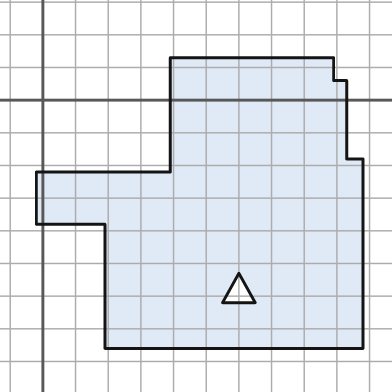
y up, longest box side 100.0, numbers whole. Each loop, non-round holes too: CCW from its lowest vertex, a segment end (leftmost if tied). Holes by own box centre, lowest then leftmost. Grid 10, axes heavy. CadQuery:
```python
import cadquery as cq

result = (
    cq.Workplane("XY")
    .moveTo(19.0, -76.0)
    .lineTo(98.0, -76.0)
    .lineTo(98.0, -18.0)
    .lineTo(93.0, -18.0)
    .lineTo(93.0, 6.0)
    .lineTo(89.0, 6.0)
    .lineTo(89.0, 13.0)
    .lineTo(39.0, 13.0)
    .lineTo(39.0, -22.0)
    .lineTo(-2.0, -22.0)
    .lineTo(-2.0, -38.0)
    .lineTo(19.0, -38.0)
    .close()
    .moveTo(55.0, -62.0)
    .lineTo(65.0, -62.0)
    .lineTo(60.0, -53.0)
    .close()
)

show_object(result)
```